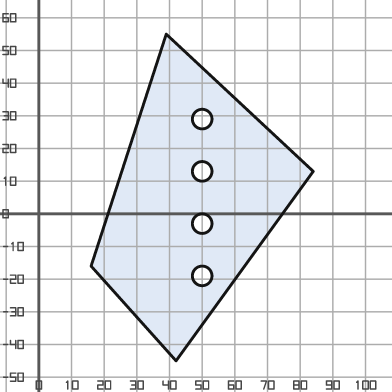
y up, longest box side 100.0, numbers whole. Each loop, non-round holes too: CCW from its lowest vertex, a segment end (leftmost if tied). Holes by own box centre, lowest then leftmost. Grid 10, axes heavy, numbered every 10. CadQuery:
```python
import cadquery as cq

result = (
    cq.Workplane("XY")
    .moveTo(42.0, -45.0)
    .lineTo(84.0, 13.0)
    .lineTo(39.0, 55.0)
    .lineTo(16.0, -16.0)
    .close()
    .moveTo(50.0, -19.0)
    .circle(3.0)
    .moveTo(50.0, -3.0)
    .circle(3.0)
    .moveTo(50.0, 13.0)
    .circle(3.0)
    .moveTo(50.0, 29.0)
    .circle(3.0)
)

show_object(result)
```